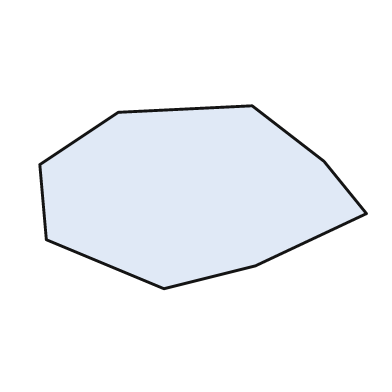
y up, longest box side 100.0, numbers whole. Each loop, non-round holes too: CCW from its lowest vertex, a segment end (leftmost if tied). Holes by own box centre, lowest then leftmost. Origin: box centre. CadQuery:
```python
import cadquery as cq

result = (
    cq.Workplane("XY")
    .moveTo(-12.0, -28.0)
    .lineTo(16.0, -21.0)
    .lineTo(50.0, -5.0)
    .lineTo(37.0, 11.0)
    .lineTo(15.0, 28.0)
    .lineTo(-26.0, 26.0)
    .lineTo(-50.0, 10.0)
    .lineTo(-48.0, -13.0)
    .close()
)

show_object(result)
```